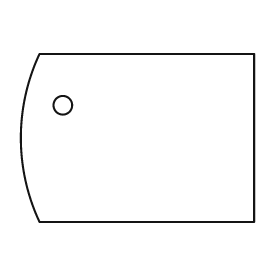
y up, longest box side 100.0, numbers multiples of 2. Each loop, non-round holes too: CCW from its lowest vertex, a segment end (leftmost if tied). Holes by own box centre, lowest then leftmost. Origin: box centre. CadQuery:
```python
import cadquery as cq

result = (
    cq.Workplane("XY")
    .moveTo(-42.0, -36.0)
    .lineTo(50.0, -36.0)
    .lineTo(50.0, 36.0)
    .lineTo(-42.0, 36.0)
    .threePointArc((-50.0, 0.0), (-42.0, -36.0))
    .close()
    .moveTo(-32.0, 14.0)
    .circle(4.0)
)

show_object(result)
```